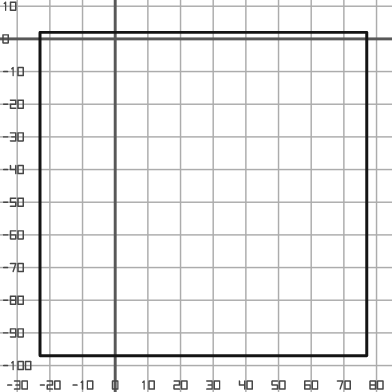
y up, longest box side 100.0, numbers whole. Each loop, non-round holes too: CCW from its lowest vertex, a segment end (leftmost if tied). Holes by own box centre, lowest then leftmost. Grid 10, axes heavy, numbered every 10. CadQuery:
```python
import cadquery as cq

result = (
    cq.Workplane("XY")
    .moveTo(-23.0, -97.0)
    .lineTo(77.0, -97.0)
    .lineTo(77.0, 2.0)
    .lineTo(-23.0, 2.0)
    .close()
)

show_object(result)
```